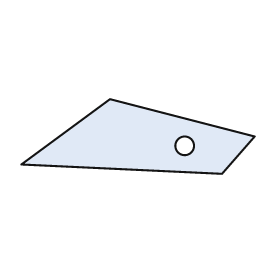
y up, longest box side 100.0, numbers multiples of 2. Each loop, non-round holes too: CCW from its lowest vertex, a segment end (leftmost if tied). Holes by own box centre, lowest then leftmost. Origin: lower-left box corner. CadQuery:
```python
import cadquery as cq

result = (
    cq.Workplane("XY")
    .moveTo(86.0, 0.0)
    .lineTo(100.0, 16.0)
    .lineTo(38.0, 32.0)
    .lineTo(0.0, 4.0)
    .close()
    .moveTo(70.0, 12.0)
    .circle(4.0)
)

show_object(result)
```